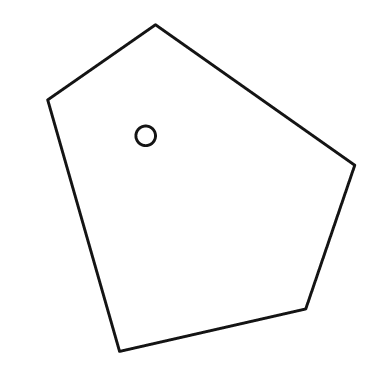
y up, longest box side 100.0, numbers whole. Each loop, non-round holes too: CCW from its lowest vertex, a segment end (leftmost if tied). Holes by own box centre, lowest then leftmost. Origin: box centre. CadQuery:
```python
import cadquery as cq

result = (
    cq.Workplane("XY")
    .moveTo(-25.0, -50.0)
    .lineTo(32.0, -37.0)
    .lineTo(47.0, 7.0)
    .lineTo(-14.0, 50.0)
    .lineTo(-47.0, 27.0)
    .close()
    .moveTo(-17.0, 16.0)
    .circle(3.0)
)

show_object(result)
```